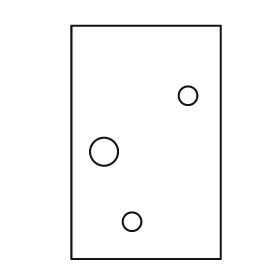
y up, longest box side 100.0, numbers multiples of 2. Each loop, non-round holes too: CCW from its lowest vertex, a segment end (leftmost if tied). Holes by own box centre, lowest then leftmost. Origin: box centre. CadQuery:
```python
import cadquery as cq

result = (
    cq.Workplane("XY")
    .moveTo(-32.0, -50.0)
    .lineTo(32.0, -50.0)
    .lineTo(32.0, 50.0)
    .lineTo(-32.0, 50.0)
    .close()
    .moveTo(-6.0, -34.0)
    .circle(4.0)
    .moveTo(-18.0, -4.0)
    .circle(6.0)
    .moveTo(18.0, 20.0)
    .circle(4.0)
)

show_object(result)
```